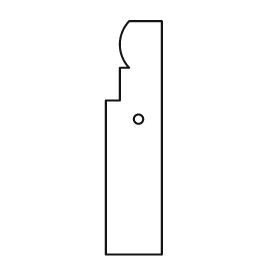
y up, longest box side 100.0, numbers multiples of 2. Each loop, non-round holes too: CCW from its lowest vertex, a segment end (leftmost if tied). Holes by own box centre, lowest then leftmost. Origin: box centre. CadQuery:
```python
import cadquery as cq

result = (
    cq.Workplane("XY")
    .moveTo(-12.0, -50.0)
    .lineTo(12.0, -50.0)
    .lineTo(12.0, 50.0)
    .lineTo(-2.0, 50.0)
    .threePointArc((-6.0, 40.0), (-2.0, 30.0))
    .lineTo(-6.0, 30.0)
    .lineTo(-6.0, 16.0)
    .lineTo(-12.0, 16.0)
    .close()
    .moveTo(2.0, 8.0)
    .circle(2.0)
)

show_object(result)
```